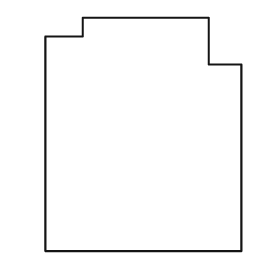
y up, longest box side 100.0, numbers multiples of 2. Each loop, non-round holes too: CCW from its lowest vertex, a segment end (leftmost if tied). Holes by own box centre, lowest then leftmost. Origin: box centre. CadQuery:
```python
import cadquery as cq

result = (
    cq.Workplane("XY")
    .moveTo(-42.0, -50.0)
    .lineTo(42.0, -50.0)
    .lineTo(42.0, 30.0)
    .lineTo(28.0, 30.0)
    .lineTo(28.0, 50.0)
    .lineTo(-26.0, 50.0)
    .lineTo(-26.0, 42.0)
    .lineTo(-42.0, 42.0)
    .close()
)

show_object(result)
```